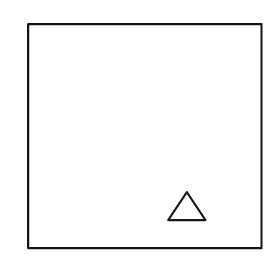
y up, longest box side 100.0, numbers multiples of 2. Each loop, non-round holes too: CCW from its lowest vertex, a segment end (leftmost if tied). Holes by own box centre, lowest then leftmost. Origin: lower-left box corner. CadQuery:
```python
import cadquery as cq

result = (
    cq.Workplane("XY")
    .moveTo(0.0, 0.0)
    .lineTo(100.0, 0.0)
    .lineTo(100.0, 96.0)
    .lineTo(0.0, 96.0)
    .close()
    .moveTo(60.0, 12.0)
    .lineTo(76.0, 12.0)
    .lineTo(68.0, 24.0)
    .close()
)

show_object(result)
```